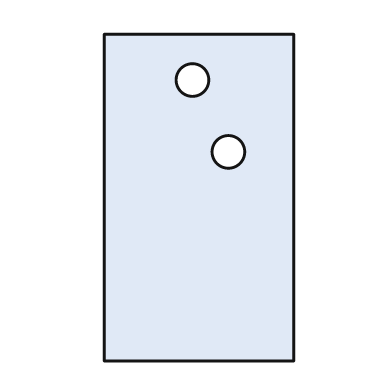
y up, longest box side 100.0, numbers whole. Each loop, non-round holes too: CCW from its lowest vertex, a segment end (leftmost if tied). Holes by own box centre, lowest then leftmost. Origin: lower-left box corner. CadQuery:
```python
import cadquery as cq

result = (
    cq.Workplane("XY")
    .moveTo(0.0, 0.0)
    .lineTo(58.0, 0.0)
    .lineTo(58.0, 100.0)
    .lineTo(0.0, 100.0)
    .close()
    .moveTo(38.0, 64.0)
    .circle(5.0)
    .moveTo(27.0, 86.0)
    .circle(5.0)
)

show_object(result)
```